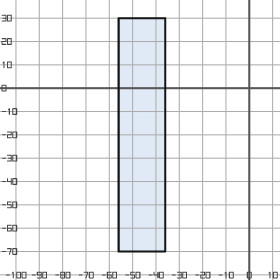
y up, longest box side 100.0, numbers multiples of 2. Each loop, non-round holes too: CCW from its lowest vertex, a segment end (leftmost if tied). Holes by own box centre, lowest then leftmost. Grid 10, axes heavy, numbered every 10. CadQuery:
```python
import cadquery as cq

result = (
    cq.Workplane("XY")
    .moveTo(-56.0, -70.0)
    .lineTo(-36.0, -70.0)
    .lineTo(-36.0, 30.0)
    .lineTo(-56.0, 30.0)
    .close()
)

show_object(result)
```